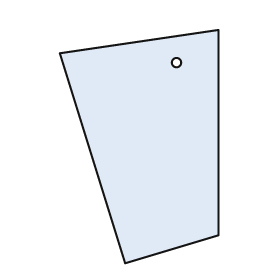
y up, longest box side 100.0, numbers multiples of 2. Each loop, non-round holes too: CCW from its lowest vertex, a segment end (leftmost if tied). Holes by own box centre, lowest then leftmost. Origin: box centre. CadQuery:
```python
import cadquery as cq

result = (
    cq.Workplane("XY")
    .moveTo(-6.0, -50.0)
    .lineTo(34.0, -38.0)
    .lineTo(34.0, 50.0)
    .lineTo(-34.0, 40.0)
    .close()
    .moveTo(16.0, 36.0)
    .circle(2.0)
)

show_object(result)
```